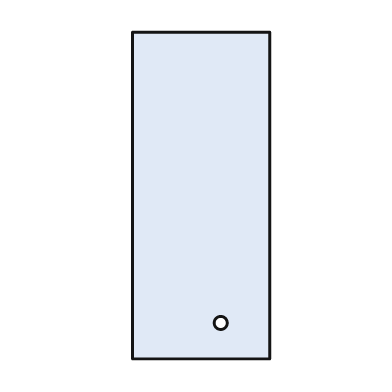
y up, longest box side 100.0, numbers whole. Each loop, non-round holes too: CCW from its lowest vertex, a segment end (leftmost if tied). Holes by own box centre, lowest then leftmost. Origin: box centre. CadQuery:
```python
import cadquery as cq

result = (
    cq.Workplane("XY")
    .moveTo(-21.0, -50.0)
    .lineTo(21.0, -50.0)
    .lineTo(21.0, 50.0)
    .lineTo(-21.0, 50.0)
    .close()
    .moveTo(6.0, -39.0)
    .circle(2.0)
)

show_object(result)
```